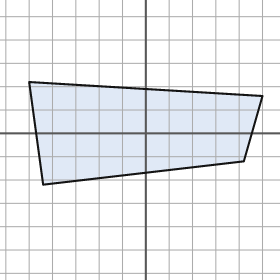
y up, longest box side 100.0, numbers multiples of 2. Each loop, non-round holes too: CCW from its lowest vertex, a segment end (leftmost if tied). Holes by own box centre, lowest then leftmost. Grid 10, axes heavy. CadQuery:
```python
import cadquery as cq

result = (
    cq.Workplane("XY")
    .moveTo(-44.0, -22.0)
    .lineTo(42.0, -12.0)
    .lineTo(50.0, 16.0)
    .lineTo(-50.0, 22.0)
    .close()
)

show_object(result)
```